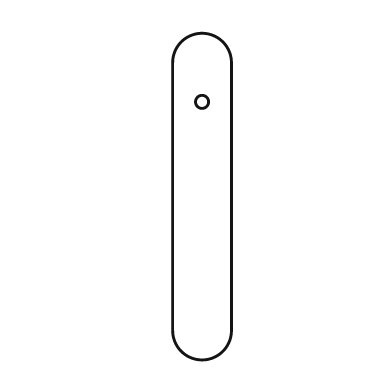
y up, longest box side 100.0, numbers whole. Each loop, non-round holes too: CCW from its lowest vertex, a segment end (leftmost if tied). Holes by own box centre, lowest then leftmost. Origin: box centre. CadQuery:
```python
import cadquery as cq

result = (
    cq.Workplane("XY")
    .moveTo(-9.0, -41.0)
    .threePointArc((0.0, -50.0), (9.0, -41.0))
    .lineTo(9.0, 41.0)
    .threePointArc((0.0, 50.0), (-9.0, 41.0))
    .close()
    .moveTo(0.0, 29.0)
    .circle(2.0)
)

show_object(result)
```